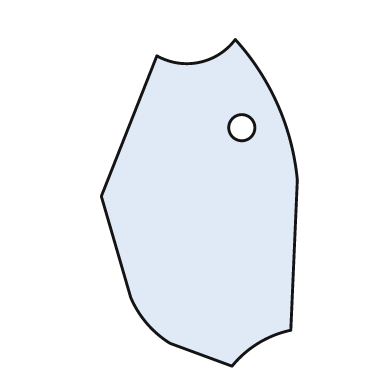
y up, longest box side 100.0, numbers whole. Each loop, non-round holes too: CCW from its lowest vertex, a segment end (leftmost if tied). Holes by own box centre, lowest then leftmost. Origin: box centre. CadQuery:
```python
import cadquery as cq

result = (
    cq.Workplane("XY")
    .moveTo(10.0, -50.0)
    .threePointArc((18.0, -43.0), (28.0, -39.0))
    .lineTo(30.0, 7.0)
    .threePointArc((24.0, 30.0), (11.0, 50.0))
    .threePointArc((0.0, 43.0), (-13.0, 45.0))
    .lineTo(-30.0, 2.0)
    .lineTo(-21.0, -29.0)
    .threePointArc((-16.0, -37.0), (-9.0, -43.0))
    .close()
    .moveTo(13.0, 23.0)
    .circle(4.0)
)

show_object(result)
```